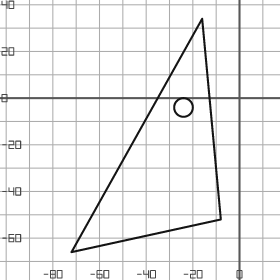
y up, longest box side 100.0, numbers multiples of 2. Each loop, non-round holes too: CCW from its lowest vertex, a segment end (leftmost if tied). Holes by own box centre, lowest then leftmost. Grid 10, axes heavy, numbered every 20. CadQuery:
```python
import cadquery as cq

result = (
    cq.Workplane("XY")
    .moveTo(-72.0, -66.0)
    .lineTo(-8.0, -52.0)
    .lineTo(-16.0, 34.0)
    .close()
    .moveTo(-24.0, -4.0)
    .circle(4.0)
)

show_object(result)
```